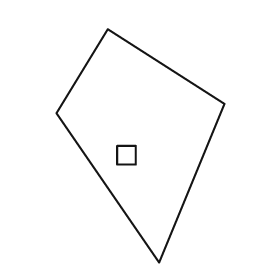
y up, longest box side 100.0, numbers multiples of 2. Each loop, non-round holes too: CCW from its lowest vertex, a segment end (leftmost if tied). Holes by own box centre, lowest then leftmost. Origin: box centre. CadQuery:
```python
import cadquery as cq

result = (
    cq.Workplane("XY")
    .moveTo(8.0, -50.0)
    .lineTo(36.0, 18.0)
    .lineTo(-14.0, 50.0)
    .lineTo(-36.0, 14.0)
    .close()
    .moveTo(-10.0, -8.0)
    .lineTo(-2.0, -8.0)
    .lineTo(-2.0, 0.0)
    .lineTo(-10.0, 0.0)
    .close()
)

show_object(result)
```